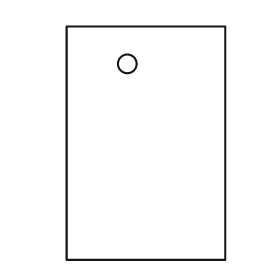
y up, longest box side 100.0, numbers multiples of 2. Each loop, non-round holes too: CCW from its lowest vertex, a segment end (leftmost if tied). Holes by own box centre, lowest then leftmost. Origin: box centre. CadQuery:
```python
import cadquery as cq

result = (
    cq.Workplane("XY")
    .moveTo(-34.0, -50.0)
    .lineTo(34.0, -50.0)
    .lineTo(34.0, 50.0)
    .lineTo(-34.0, 50.0)
    .close()
    .moveTo(-8.0, 34.0)
    .circle(4.0)
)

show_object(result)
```